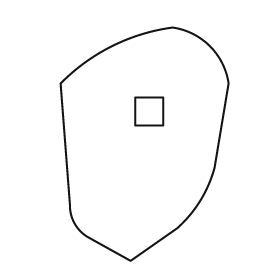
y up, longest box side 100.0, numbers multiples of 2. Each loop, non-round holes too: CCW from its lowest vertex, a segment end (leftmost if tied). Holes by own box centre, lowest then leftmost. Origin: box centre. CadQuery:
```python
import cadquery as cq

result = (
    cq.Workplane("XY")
    .moveTo(-6.0, -50.0)
    .lineTo(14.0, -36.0)
    .threePointArc((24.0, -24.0), (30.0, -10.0))
    .lineTo(36.0, 26.0)
    .threePointArc((28.0, 42.0), (12.0, 50.0))
    .threePointArc((-14.0, 42.0), (-36.0, 26.0))
    .lineTo(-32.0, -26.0)
    .threePointArc((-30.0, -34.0), (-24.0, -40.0))
    .close()
    .moveTo(-4.0, 8.0)
    .lineTo(8.0, 8.0)
    .lineTo(8.0, 20.0)
    .lineTo(-4.0, 20.0)
    .close()
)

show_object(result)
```